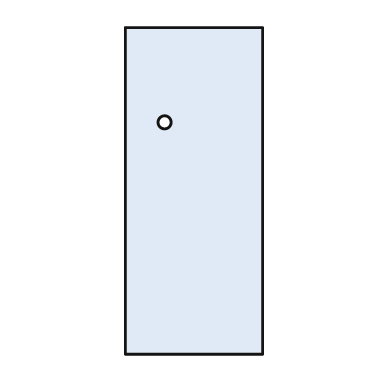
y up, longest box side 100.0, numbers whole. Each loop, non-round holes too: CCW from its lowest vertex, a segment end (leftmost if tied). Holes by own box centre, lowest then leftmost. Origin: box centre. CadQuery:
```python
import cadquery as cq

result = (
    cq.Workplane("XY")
    .moveTo(-21.0, -50.0)
    .lineTo(21.0, -50.0)
    .lineTo(21.0, 50.0)
    .lineTo(-21.0, 50.0)
    .close()
    .moveTo(-9.0, 21.0)
    .circle(2.0)
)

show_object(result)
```